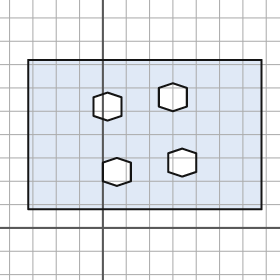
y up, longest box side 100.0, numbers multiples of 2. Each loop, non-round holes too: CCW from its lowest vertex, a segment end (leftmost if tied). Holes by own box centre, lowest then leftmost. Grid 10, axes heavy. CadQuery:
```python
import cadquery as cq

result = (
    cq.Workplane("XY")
    .moveTo(-32.0, 8.0)
    .lineTo(68.0, 8.0)
    .lineTo(68.0, 72.0)
    .lineTo(-32.0, 72.0)
    .close()
    .moveTo(6.0, 18.0)
    .lineTo(12.0, 20.0)
    .lineTo(12.0, 28.0)
    .lineTo(6.0, 30.0)
    .lineTo(0.0, 28.0)
    .lineTo(0.0, 20.0)
    .close()
    .moveTo(34.0, 22.0)
    .lineTo(40.0, 24.0)
    .lineTo(40.0, 32.0)
    .lineTo(34.0, 34.0)
    .lineTo(28.0, 32.0)
    .lineTo(28.0, 24.0)
    .close()
    .moveTo(2.0, 46.0)
    .lineTo(8.0, 48.0)
    .lineTo(8.0, 56.0)
    .lineTo(2.0, 58.0)
    .lineTo(-4.0, 56.0)
    .lineTo(-4.0, 48.0)
    .close()
    .moveTo(30.0, 50.0)
    .lineTo(36.0, 52.0)
    .lineTo(36.0, 60.0)
    .lineTo(30.0, 62.0)
    .lineTo(24.0, 60.0)
    .lineTo(24.0, 52.0)
    .close()
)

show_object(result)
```